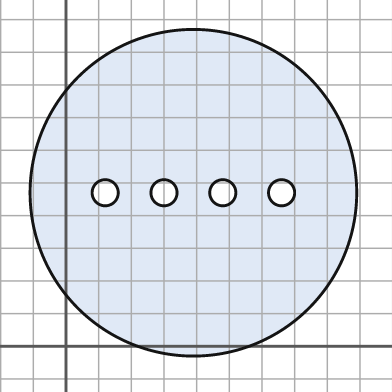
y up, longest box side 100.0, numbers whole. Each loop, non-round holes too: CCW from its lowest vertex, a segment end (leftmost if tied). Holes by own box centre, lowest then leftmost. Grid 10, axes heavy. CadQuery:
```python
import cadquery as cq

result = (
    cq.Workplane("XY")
    .moveTo(39.0, 47.0)
    .circle(50.0)
    .moveTo(12.0, 47.0)
    .circle(4.0)
    .moveTo(30.0, 47.0)
    .circle(4.0)
    .moveTo(48.0, 47.0)
    .circle(4.0)
    .moveTo(66.0, 47.0)
    .circle(4.0)
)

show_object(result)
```